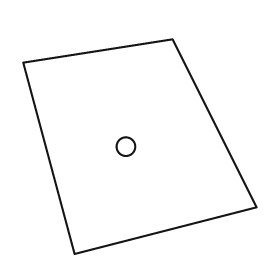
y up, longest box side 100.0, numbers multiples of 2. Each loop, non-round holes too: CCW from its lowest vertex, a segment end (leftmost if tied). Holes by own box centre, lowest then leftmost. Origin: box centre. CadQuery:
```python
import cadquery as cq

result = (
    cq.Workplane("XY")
    .moveTo(-28.0, -46.0)
    .lineTo(50.0, -26.0)
    .lineTo(14.0, 46.0)
    .lineTo(-50.0, 36.0)
    .close()
    .moveTo(-6.0, 0.0)
    .circle(4.0)
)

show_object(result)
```